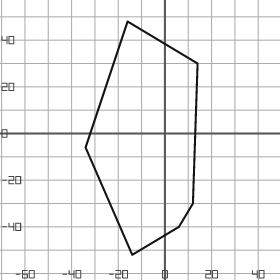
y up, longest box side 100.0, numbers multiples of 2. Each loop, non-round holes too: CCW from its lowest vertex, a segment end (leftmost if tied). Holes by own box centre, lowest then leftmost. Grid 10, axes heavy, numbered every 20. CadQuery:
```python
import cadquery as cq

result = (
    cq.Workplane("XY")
    .moveTo(-14.0, -52.0)
    .lineTo(6.0, -40.0)
    .lineTo(12.0, -30.0)
    .lineTo(14.0, 30.0)
    .lineTo(-16.0, 48.0)
    .lineTo(-34.0, -6.0)
    .close()
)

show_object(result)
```